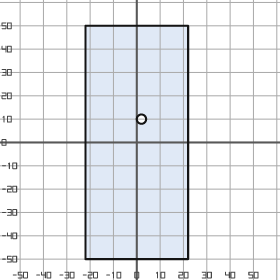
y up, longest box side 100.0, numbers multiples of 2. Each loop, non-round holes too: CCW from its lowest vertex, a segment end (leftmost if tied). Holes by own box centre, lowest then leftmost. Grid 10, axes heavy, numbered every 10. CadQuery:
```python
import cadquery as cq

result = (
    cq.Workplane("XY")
    .moveTo(-22.0, -50.0)
    .lineTo(22.0, -50.0)
    .lineTo(22.0, 50.0)
    .lineTo(-22.0, 50.0)
    .close()
    .moveTo(2.0, 10.0)
    .circle(2.0)
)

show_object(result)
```